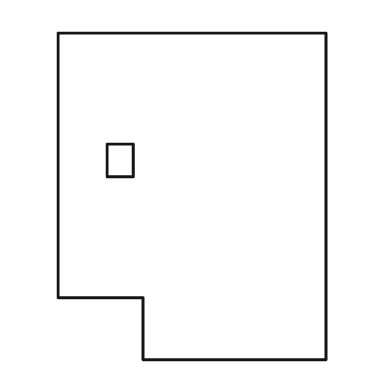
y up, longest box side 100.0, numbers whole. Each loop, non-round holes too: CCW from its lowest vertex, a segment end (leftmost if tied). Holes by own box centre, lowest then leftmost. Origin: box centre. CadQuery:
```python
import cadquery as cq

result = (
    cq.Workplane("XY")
    .moveTo(-15.0, -50.0)
    .lineTo(41.0, -50.0)
    .lineTo(41.0, 50.0)
    .lineTo(-41.0, 50.0)
    .lineTo(-41.0, -31.0)
    .lineTo(-15.0, -31.0)
    .close()
    .moveTo(-26.0, 6.0)
    .lineTo(-18.0, 6.0)
    .lineTo(-18.0, 16.0)
    .lineTo(-26.0, 16.0)
    .close()
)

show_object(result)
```